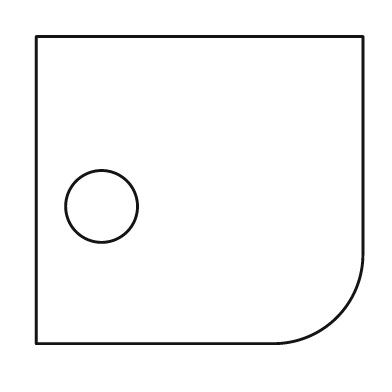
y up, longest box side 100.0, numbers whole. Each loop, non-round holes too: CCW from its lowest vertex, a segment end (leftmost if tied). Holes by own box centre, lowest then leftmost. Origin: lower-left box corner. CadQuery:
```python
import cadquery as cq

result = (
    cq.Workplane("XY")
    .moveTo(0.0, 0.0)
    .lineTo(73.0, 0.0)
    .threePointArc((92.0, 8.0), (100.0, 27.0))
    .lineTo(100.0, 94.0)
    .lineTo(0.0, 94.0)
    .close()
    .moveTo(20.0, 42.0)
    .circle(11.0)
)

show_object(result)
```